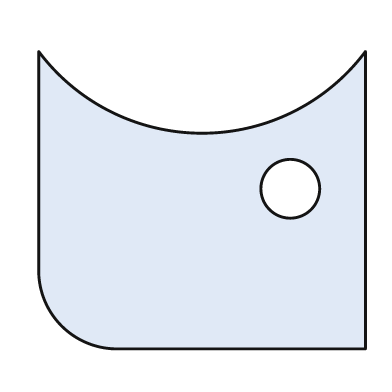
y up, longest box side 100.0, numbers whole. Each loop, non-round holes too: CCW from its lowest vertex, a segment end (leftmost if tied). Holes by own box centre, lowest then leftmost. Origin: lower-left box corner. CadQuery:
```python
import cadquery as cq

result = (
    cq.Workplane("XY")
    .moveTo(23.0, 0.0)
    .lineTo(100.0, 0.0)
    .lineTo(100.0, 91.0)
    .threePointArc((50.0, 66.0), (0.0, 91.0))
    .lineTo(0.0, 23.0)
    .threePointArc((7.0, 7.0), (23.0, 0.0))
    .close()
    .moveTo(77.0, 49.0)
    .circle(9.0)
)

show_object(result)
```